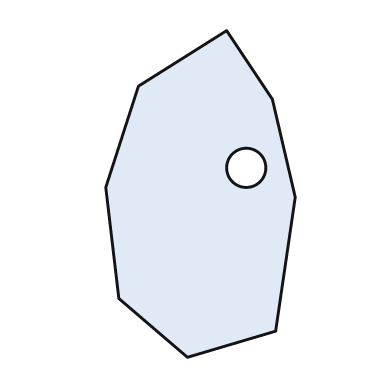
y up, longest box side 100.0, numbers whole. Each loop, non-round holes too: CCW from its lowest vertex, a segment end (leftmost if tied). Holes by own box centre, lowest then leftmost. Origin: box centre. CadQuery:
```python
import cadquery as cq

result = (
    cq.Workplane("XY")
    .moveTo(-4.0, -50.0)
    .lineTo(23.0, -42.0)
    .lineTo(29.0, -1.0)
    .lineTo(22.0, 29.0)
    .lineTo(8.0, 50.0)
    .lineTo(-19.0, 33.0)
    .lineTo(-29.0, 2.0)
    .lineTo(-25.0, -32.0)
    .close()
    .moveTo(14.0, 8.0)
    .circle(6.0)
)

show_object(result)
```